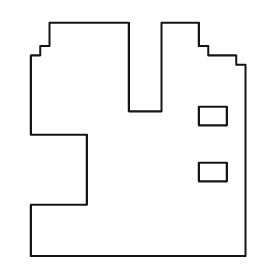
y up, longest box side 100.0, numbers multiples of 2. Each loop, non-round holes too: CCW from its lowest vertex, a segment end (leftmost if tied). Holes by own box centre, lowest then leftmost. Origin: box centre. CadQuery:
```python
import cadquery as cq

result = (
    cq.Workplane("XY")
    .moveTo(-46.0, -50.0)
    .lineTo(46.0, -50.0)
    .lineTo(46.0, 32.0)
    .lineTo(42.0, 32.0)
    .lineTo(42.0, 36.0)
    .lineTo(30.0, 36.0)
    .lineTo(30.0, 40.0)
    .lineTo(26.0, 40.0)
    .lineTo(26.0, 50.0)
    .lineTo(10.0, 50.0)
    .lineTo(10.0, 12.0)
    .lineTo(-4.0, 12.0)
    .lineTo(-4.0, 50.0)
    .lineTo(-38.0, 50.0)
    .lineTo(-38.0, 40.0)
    .lineTo(-42.0, 40.0)
    .lineTo(-42.0, 36.0)
    .lineTo(-46.0, 36.0)
    .lineTo(-46.0, 2.0)
    .lineTo(-22.0, 2.0)
    .lineTo(-22.0, -28.0)
    .lineTo(-46.0, -28.0)
    .close()
    .moveTo(26.0, -18.0)
    .lineTo(38.0, -18.0)
    .lineTo(38.0, -10.0)
    .lineTo(26.0, -10.0)
    .close()
    .moveTo(26.0, 6.0)
    .lineTo(38.0, 6.0)
    .lineTo(38.0, 14.0)
    .lineTo(26.0, 14.0)
    .close()
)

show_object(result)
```